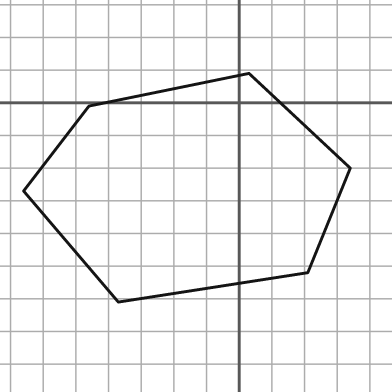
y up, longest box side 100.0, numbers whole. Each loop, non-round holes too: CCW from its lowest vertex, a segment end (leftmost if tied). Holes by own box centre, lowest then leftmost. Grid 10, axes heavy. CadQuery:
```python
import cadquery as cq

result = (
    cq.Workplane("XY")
    .moveTo(-37.0, -61.0)
    .lineTo(21.0, -52.0)
    .lineTo(34.0, -20.0)
    .lineTo(3.0, 9.0)
    .lineTo(-46.0, -1.0)
    .lineTo(-66.0, -27.0)
    .close()
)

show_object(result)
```